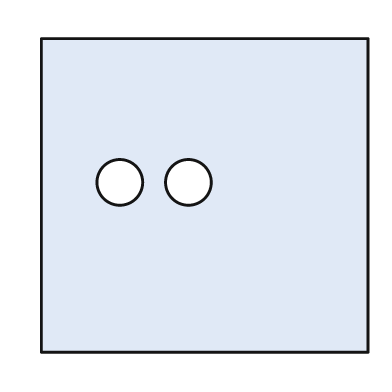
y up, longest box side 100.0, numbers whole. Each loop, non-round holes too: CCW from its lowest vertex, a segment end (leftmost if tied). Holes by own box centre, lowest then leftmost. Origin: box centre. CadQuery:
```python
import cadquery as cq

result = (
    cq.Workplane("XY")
    .moveTo(-50.0, -48.0)
    .lineTo(50.0, -48.0)
    .lineTo(50.0, 48.0)
    .lineTo(-50.0, 48.0)
    .close()
    .moveTo(-26.0, 4.0)
    .circle(7.0)
    .moveTo(-5.0, 4.0)
    .circle(7.0)
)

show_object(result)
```